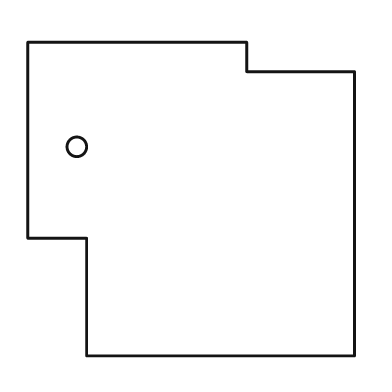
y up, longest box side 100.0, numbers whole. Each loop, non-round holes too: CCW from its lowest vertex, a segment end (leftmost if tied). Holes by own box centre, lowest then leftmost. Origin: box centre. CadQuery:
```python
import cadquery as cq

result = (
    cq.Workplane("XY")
    .moveTo(-32.0, -48.0)
    .lineTo(50.0, -48.0)
    .lineTo(50.0, 39.0)
    .lineTo(17.0, 39.0)
    .lineTo(17.0, 48.0)
    .lineTo(-50.0, 48.0)
    .lineTo(-50.0, -12.0)
    .lineTo(-32.0, -12.0)
    .close()
    .moveTo(-35.0, 16.0)
    .circle(3.0)
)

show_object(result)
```